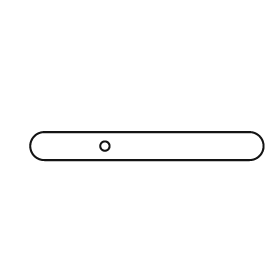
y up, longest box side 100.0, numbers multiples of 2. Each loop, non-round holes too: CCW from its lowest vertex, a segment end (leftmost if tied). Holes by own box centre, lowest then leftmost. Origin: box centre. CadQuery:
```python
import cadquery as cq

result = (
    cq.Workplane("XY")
    .moveTo(-44.0, -6.0)
    .lineTo(44.0, -6.0)
    .threePointArc((50.0, 0.0), (44.0, 6.0))
    .lineTo(-44.0, 6.0)
    .threePointArc((-50.0, 0.0), (-44.0, -6.0))
    .close()
    .moveTo(-18.0, 0.0)
    .circle(2.0)
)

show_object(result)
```